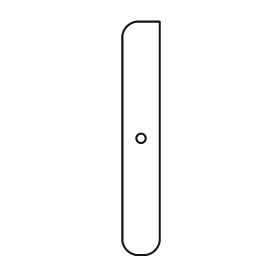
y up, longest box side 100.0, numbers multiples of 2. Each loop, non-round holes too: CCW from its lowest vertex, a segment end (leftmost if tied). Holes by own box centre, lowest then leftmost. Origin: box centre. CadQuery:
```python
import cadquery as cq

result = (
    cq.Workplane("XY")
    .moveTo(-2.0, -50.0)
    .lineTo(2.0, -50.0)
    .threePointArc((6.0, -48.0), (8.0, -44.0))
    .lineTo(8.0, 50.0)
    .lineTo(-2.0, 50.0)
    .threePointArc((-6.0, 48.0), (-8.0, 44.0))
    .lineTo(-8.0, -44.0)
    .threePointArc((-6.0, -48.0), (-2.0, -50.0))
    .close()
    .moveTo(0.0, 0.0)
    .circle(2.0)
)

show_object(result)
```